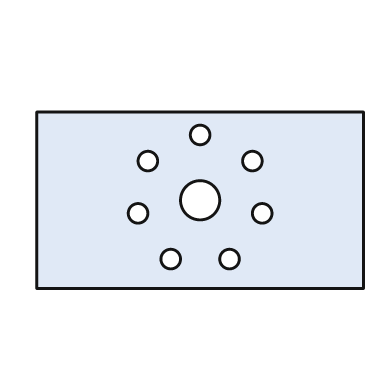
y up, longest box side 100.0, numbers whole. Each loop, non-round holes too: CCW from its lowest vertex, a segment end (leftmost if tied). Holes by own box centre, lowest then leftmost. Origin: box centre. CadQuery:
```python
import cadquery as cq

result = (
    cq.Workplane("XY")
    .moveTo(-50.0, -27.0)
    .lineTo(50.0, -27.0)
    .lineTo(50.0, 27.0)
    .lineTo(-50.0, 27.0)
    .close()
    .moveTo(-9.0, -18.0)
    .circle(3.0)
    .moveTo(9.0, -18.0)
    .circle(3.0)
    .moveTo(-19.0, -4.0)
    .circle(3.0)
    .moveTo(19.0, -4.0)
    .circle(3.0)
    .moveTo(0.0, 0.0)
    .circle(6.0)
    .moveTo(-16.0, 12.0)
    .circle(3.0)
    .moveTo(16.0, 12.0)
    .circle(3.0)
    .moveTo(0.0, 20.0)
    .circle(3.0)
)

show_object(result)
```